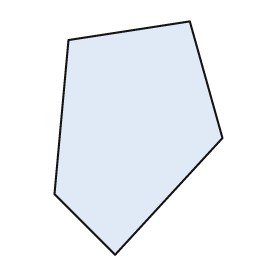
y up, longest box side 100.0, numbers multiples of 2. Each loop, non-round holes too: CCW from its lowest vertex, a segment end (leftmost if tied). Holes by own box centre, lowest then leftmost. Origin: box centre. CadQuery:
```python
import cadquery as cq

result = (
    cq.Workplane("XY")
    .moveTo(-10.0, -50.0)
    .lineTo(36.0, 0.0)
    .lineTo(22.0, 50.0)
    .lineTo(-30.0, 42.0)
    .lineTo(-36.0, -24.0)
    .close()
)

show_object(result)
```